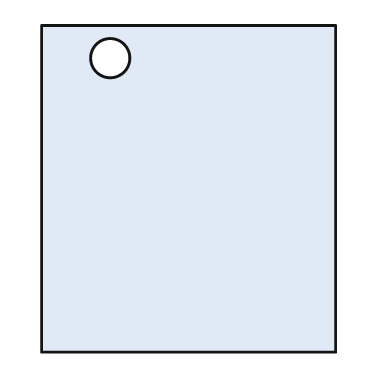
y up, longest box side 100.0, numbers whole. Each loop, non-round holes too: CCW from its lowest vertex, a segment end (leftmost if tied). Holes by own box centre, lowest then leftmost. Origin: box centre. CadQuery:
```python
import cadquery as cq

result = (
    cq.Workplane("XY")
    .moveTo(-45.0, -50.0)
    .lineTo(45.0, -50.0)
    .lineTo(45.0, 50.0)
    .lineTo(-45.0, 50.0)
    .close()
    .moveTo(-24.0, 40.0)
    .circle(6.0)
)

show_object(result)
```